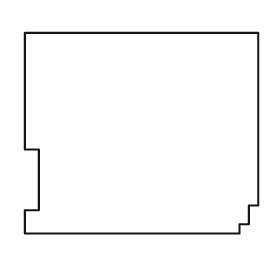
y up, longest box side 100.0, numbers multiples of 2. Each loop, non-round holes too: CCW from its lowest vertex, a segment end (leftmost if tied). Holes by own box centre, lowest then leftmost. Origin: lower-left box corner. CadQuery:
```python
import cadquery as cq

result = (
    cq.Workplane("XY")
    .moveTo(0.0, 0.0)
    .lineTo(92.0, 0.0)
    .lineTo(92.0, 4.0)
    .lineTo(96.0, 4.0)
    .lineTo(96.0, 12.0)
    .lineTo(100.0, 12.0)
    .lineTo(100.0, 86.0)
    .lineTo(0.0, 86.0)
    .lineTo(0.0, 36.0)
    .lineTo(6.0, 36.0)
    .lineTo(6.0, 10.0)
    .lineTo(0.0, 10.0)
    .close()
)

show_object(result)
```